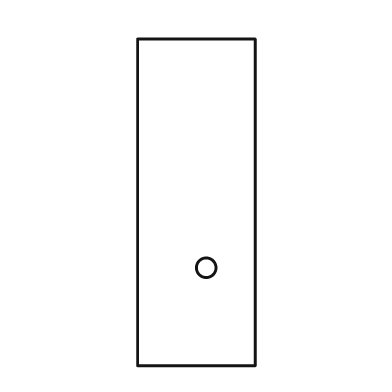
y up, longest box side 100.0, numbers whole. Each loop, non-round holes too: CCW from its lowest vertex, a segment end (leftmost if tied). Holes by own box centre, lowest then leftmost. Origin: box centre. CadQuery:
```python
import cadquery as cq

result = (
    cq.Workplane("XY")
    .moveTo(-18.0, -50.0)
    .lineTo(18.0, -50.0)
    .lineTo(18.0, 50.0)
    .lineTo(-18.0, 50.0)
    .close()
    .moveTo(3.0, -20.0)
    .circle(3.0)
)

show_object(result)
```